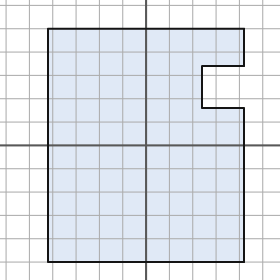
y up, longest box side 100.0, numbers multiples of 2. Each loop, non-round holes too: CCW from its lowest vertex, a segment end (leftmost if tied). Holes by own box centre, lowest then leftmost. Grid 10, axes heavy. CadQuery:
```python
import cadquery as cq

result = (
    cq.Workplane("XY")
    .moveTo(-42.0, -50.0)
    .lineTo(42.0, -50.0)
    .lineTo(42.0, 16.0)
    .lineTo(24.0, 16.0)
    .lineTo(24.0, 34.0)
    .lineTo(42.0, 34.0)
    .lineTo(42.0, 50.0)
    .lineTo(-42.0, 50.0)
    .close()
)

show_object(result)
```